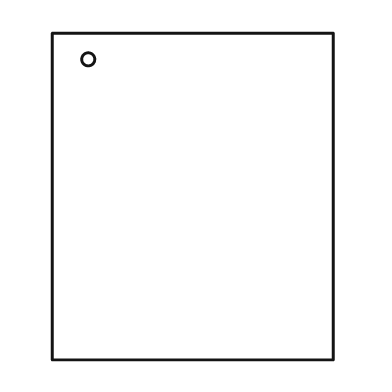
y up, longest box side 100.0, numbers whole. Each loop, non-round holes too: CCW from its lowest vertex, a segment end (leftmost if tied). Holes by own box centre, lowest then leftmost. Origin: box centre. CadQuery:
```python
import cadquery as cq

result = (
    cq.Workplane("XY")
    .moveTo(-43.0, -50.0)
    .lineTo(43.0, -50.0)
    .lineTo(43.0, 50.0)
    .lineTo(-43.0, 50.0)
    .close()
    .moveTo(-32.0, 42.0)
    .circle(2.0)
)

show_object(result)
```